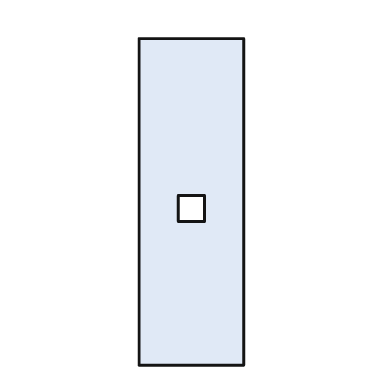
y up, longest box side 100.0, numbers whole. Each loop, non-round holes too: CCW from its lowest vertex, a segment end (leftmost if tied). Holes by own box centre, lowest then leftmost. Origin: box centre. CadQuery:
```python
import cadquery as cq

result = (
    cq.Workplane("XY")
    .moveTo(-16.0, -50.0)
    .lineTo(16.0, -50.0)
    .lineTo(16.0, 50.0)
    .lineTo(-16.0, 50.0)
    .close()
    .moveTo(-4.0, -6.0)
    .lineTo(4.0, -6.0)
    .lineTo(4.0, 2.0)
    .lineTo(-4.0, 2.0)
    .close()
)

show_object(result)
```